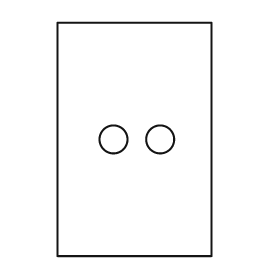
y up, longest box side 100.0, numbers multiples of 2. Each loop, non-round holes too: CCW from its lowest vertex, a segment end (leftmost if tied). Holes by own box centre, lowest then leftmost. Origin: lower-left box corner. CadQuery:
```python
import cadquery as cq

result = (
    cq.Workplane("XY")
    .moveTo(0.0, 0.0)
    .lineTo(66.0, 0.0)
    .lineTo(66.0, 100.0)
    .lineTo(0.0, 100.0)
    .close()
    .moveTo(24.0, 50.0)
    .circle(6.0)
    .moveTo(44.0, 50.0)
    .circle(6.0)
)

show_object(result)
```